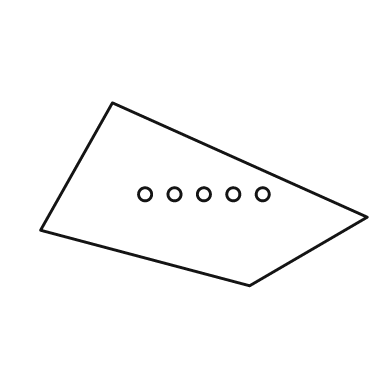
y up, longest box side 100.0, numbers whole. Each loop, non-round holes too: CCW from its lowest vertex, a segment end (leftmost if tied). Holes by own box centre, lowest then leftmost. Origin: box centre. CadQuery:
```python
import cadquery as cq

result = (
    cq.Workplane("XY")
    .moveTo(14.0, -28.0)
    .lineTo(50.0, -7.0)
    .lineTo(-28.0, 28.0)
    .lineTo(-50.0, -11.0)
    .close()
    .moveTo(-18.0, 0.0)
    .circle(2.0)
    .moveTo(-9.0, 0.0)
    .circle(2.0)
    .moveTo(0.0, 0.0)
    .circle(2.0)
    .moveTo(9.0, 0.0)
    .circle(2.0)
    .moveTo(18.0, 0.0)
    .circle(2.0)
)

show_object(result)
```